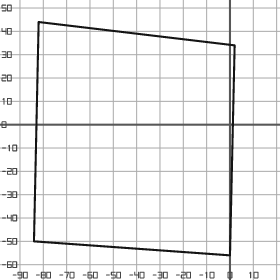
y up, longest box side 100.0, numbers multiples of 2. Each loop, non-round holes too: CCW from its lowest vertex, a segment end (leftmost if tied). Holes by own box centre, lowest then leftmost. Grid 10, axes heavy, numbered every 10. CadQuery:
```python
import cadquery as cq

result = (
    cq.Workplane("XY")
    .moveTo(0.0, -56.0)
    .lineTo(2.0, 34.0)
    .lineTo(-82.0, 44.0)
    .lineTo(-84.0, -50.0)
    .close()
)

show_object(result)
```